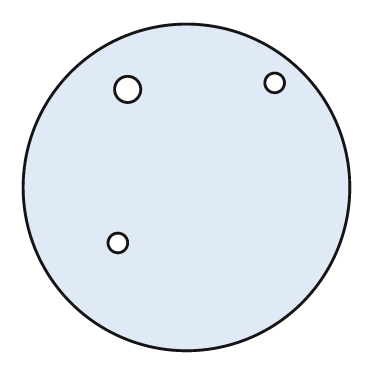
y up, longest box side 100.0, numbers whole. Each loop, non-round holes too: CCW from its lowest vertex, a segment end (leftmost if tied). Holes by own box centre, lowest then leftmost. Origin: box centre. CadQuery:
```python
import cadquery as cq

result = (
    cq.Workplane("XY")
    .moveTo(0.0, 0.0)
    .circle(50.0)
    .moveTo(-21.0, -17.0)
    .circle(3.0)
    .moveTo(-18.0, 30.0)
    .circle(4.0)
    .moveTo(27.0, 32.0)
    .circle(3.0)
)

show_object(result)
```